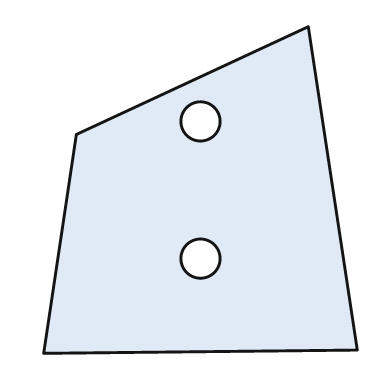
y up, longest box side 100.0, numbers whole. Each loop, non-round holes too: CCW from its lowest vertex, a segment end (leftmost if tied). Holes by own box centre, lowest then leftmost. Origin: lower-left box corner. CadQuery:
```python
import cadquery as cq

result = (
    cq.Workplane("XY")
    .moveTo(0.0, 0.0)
    .lineTo(96.0, 1.0)
    .lineTo(81.0, 100.0)
    .lineTo(10.0, 67.0)
    .close()
    .moveTo(48.0, 29.0)
    .circle(6.0)
    .moveTo(48.0, 71.0)
    .circle(6.0)
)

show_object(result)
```